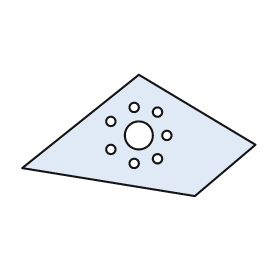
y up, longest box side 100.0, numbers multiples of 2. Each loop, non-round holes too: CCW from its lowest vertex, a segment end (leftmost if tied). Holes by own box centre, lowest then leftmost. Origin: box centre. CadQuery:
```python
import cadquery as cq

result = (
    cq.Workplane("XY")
    .moveTo(24.0, -26.0)
    .lineTo(50.0, -4.0)
    .lineTo(0.0, 26.0)
    .lineTo(-50.0, -14.0)
    .close()
    .moveTo(-2.0, -12.0)
    .circle(2.0)
    .moveTo(8.0, -10.0)
    .circle(2.0)
    .moveTo(-12.0, -6.0)
    .circle(2.0)
    .moveTo(0.0, 0.0)
    .circle(6.0)
    .moveTo(12.0, 0.0)
    .circle(2.0)
    .moveTo(-12.0, 6.0)
    .circle(2.0)
    .moveTo(8.0, 10.0)
    .circle(2.0)
    .moveTo(-2.0, 12.0)
    .circle(2.0)
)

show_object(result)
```